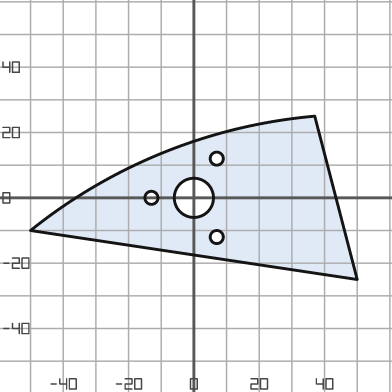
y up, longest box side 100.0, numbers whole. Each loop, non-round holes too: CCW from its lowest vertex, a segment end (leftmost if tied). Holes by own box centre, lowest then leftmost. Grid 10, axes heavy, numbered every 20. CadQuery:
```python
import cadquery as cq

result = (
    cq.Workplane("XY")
    .moveTo(50.0, -25.0)
    .lineTo(37.0, 25.0)
    .threePointArc((-9.0, 14.0), (-50.0, -10.0))
    .close()
    .moveTo(7.0, -12.0)
    .circle(2.0)
    .moveTo(-13.0, 0.0)
    .circle(2.0)
    .moveTo(0.0, 0.0)
    .circle(6.0)
    .moveTo(7.0, 12.0)
    .circle(2.0)
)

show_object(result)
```